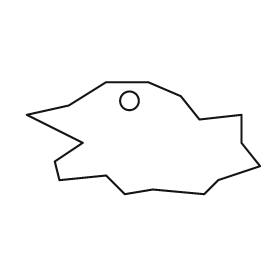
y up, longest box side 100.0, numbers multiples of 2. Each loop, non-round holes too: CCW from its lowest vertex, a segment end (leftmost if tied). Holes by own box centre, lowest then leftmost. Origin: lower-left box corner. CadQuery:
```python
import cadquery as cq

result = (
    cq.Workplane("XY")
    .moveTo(42.0, 0.0)
    .lineTo(54.0, 2.0)
    .lineTo(76.0, 0.0)
    .lineTo(82.0, 6.0)
    .lineTo(100.0, 12.0)
    .lineTo(92.0, 22.0)
    .lineTo(92.0, 34.0)
    .lineTo(74.0, 32.0)
    .lineTo(66.0, 42.0)
    .lineTo(52.0, 48.0)
    .lineTo(34.0, 48.0)
    .lineTo(18.0, 38.0)
    .lineTo(0.0, 34.0)
    .lineTo(24.0, 22.0)
    .lineTo(12.0, 14.0)
    .lineTo(14.0, 6.0)
    .lineTo(34.0, 8.0)
    .close()
    .moveTo(44.0, 40.0)
    .circle(4.0)
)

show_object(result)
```